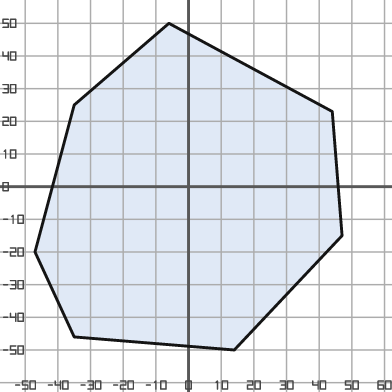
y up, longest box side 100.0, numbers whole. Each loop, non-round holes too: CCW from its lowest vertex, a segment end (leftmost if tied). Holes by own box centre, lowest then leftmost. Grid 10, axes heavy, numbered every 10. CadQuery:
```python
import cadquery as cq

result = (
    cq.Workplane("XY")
    .moveTo(14.0, -50.0)
    .lineTo(47.0, -15.0)
    .lineTo(44.0, 23.0)
    .lineTo(-6.0, 50.0)
    .lineTo(-35.0, 25.0)
    .lineTo(-47.0, -20.0)
    .lineTo(-35.0, -46.0)
    .close()
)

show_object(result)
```